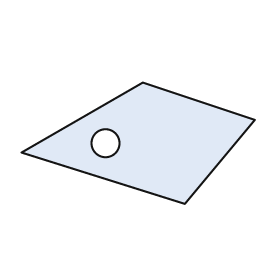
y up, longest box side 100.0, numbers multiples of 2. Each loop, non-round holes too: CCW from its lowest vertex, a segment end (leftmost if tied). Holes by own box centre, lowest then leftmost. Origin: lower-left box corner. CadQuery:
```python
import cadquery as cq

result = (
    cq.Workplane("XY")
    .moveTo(70.0, 0.0)
    .lineTo(100.0, 36.0)
    .lineTo(52.0, 52.0)
    .lineTo(0.0, 22.0)
    .close()
    .moveTo(36.0, 26.0)
    .circle(6.0)
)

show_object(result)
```